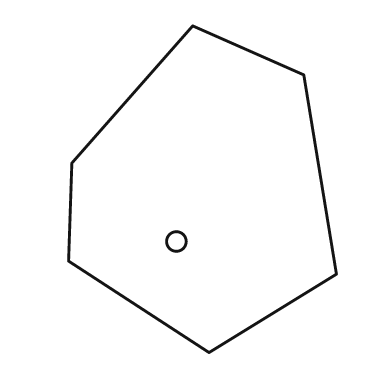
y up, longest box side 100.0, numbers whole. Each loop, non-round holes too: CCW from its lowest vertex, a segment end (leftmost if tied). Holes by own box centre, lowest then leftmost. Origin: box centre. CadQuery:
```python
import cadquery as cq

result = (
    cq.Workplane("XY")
    .moveTo(2.0, -50.0)
    .lineTo(41.0, -26.0)
    .lineTo(31.0, 35.0)
    .lineTo(-3.0, 50.0)
    .lineTo(-40.0, 8.0)
    .lineTo(-41.0, -22.0)
    .close()
    .moveTo(-8.0, -16.0)
    .circle(3.0)
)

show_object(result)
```